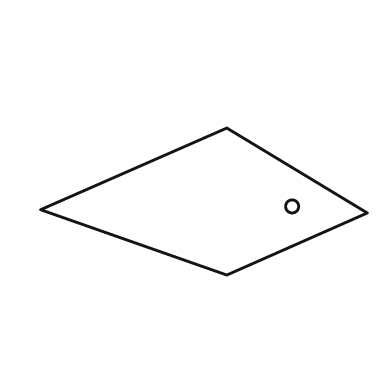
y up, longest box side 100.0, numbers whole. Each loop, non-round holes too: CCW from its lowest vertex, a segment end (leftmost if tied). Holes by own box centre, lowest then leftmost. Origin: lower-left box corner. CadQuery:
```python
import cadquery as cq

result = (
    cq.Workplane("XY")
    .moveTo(57.0, 0.0)
    .lineTo(100.0, 19.0)
    .lineTo(57.0, 45.0)
    .lineTo(0.0, 20.0)
    .close()
    .moveTo(77.0, 21.0)
    .circle(2.0)
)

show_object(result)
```